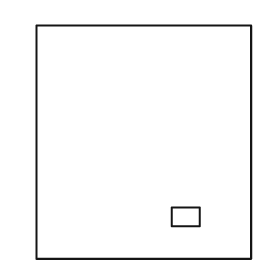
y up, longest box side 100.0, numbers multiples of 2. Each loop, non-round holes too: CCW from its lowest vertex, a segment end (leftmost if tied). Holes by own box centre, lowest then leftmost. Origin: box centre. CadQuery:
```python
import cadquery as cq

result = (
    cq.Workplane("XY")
    .moveTo(-46.0, -50.0)
    .lineTo(46.0, -50.0)
    .lineTo(46.0, 50.0)
    .lineTo(-46.0, 50.0)
    .close()
    .moveTo(12.0, -36.0)
    .lineTo(24.0, -36.0)
    .lineTo(24.0, -28.0)
    .lineTo(12.0, -28.0)
    .close()
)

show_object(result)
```